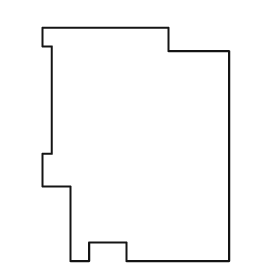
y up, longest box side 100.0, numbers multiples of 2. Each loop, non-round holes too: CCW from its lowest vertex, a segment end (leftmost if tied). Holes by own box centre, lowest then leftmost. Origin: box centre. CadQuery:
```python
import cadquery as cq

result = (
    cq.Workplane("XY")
    .moveTo(-28.0, -50.0)
    .lineTo(-20.0, -50.0)
    .lineTo(-20.0, -42.0)
    .lineTo(-4.0, -42.0)
    .lineTo(-4.0, -50.0)
    .lineTo(40.0, -50.0)
    .lineTo(40.0, 40.0)
    .lineTo(14.0, 40.0)
    .lineTo(14.0, 50.0)
    .lineTo(-40.0, 50.0)
    .lineTo(-40.0, 42.0)
    .lineTo(-36.0, 42.0)
    .lineTo(-36.0, -4.0)
    .lineTo(-40.0, -4.0)
    .lineTo(-40.0, -18.0)
    .lineTo(-28.0, -18.0)
    .close()
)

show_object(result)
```